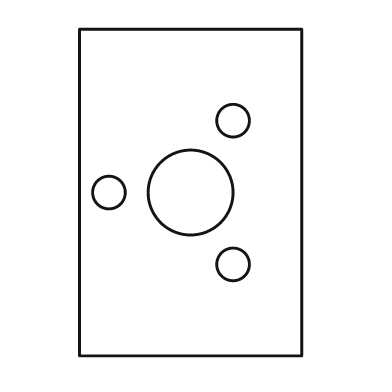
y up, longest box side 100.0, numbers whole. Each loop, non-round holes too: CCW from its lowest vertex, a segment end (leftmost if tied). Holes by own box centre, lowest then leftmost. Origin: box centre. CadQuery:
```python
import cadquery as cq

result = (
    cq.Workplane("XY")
    .moveTo(-34.0, -50.0)
    .lineTo(34.0, -50.0)
    .lineTo(34.0, 50.0)
    .lineTo(-34.0, 50.0)
    .close()
    .moveTo(13.0, -22.0)
    .circle(5.0)
    .moveTo(-25.0, 0.0)
    .circle(5.0)
    .moveTo(0.0, 0.0)
    .circle(13.0)
    .moveTo(13.0, 22.0)
    .circle(5.0)
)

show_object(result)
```